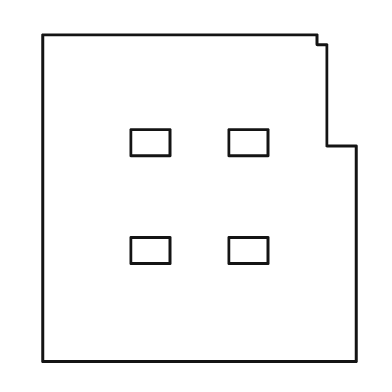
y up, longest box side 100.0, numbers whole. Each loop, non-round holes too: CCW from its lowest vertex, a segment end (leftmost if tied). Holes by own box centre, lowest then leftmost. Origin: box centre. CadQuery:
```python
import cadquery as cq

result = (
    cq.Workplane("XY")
    .moveTo(-48.0, -50.0)
    .lineTo(48.0, -50.0)
    .lineTo(48.0, 16.0)
    .lineTo(39.0, 16.0)
    .lineTo(39.0, 47.0)
    .lineTo(36.0, 47.0)
    .lineTo(36.0, 50.0)
    .lineTo(-48.0, 50.0)
    .close()
    .moveTo(-21.0, -20.0)
    .lineTo(-9.0, -20.0)
    .lineTo(-9.0, -12.0)
    .lineTo(-21.0, -12.0)
    .close()
    .moveTo(9.0, -20.0)
    .lineTo(21.0, -20.0)
    .lineTo(21.0, -12.0)
    .lineTo(9.0, -12.0)
    .close()
    .moveTo(-21.0, 13.0)
    .lineTo(-9.0, 13.0)
    .lineTo(-9.0, 21.0)
    .lineTo(-21.0, 21.0)
    .close()
    .moveTo(9.0, 13.0)
    .lineTo(21.0, 13.0)
    .lineTo(21.0, 21.0)
    .lineTo(9.0, 21.0)
    .close()
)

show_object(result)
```